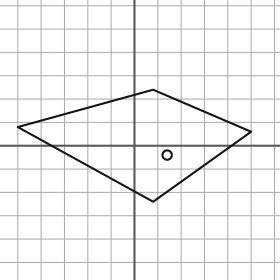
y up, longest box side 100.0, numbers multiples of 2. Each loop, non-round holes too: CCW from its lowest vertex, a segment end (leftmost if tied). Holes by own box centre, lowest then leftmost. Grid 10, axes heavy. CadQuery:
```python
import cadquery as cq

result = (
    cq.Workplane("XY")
    .moveTo(8.0, -24.0)
    .lineTo(50.0, 6.0)
    .lineTo(8.0, 24.0)
    .lineTo(-50.0, 8.0)
    .close()
    .moveTo(14.0, -4.0)
    .circle(2.0)
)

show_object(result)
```